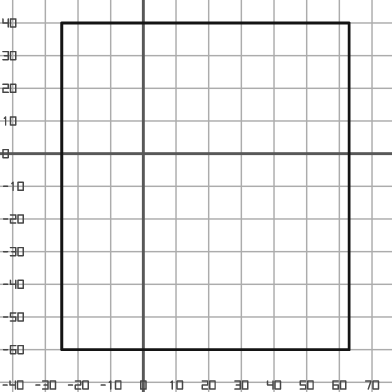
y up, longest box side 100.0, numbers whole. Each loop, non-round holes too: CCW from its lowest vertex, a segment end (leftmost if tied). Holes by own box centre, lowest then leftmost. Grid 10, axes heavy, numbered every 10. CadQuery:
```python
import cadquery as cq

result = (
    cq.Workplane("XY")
    .moveTo(-25.0, -60.0)
    .lineTo(63.0, -60.0)
    .lineTo(63.0, 40.0)
    .lineTo(-25.0, 40.0)
    .close()
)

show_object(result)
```